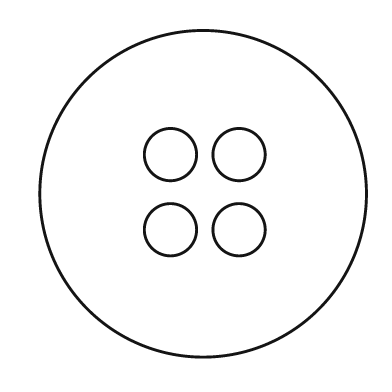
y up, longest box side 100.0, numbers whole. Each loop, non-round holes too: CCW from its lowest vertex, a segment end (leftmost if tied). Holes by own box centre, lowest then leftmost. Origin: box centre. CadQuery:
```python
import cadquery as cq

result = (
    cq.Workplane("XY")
    .moveTo(0.0, 0.0)
    .circle(50.0)
    .moveTo(-10.0, -11.0)
    .circle(8.0)
    .moveTo(11.0, -11.0)
    .circle(8.0)
    .moveTo(-10.0, 12.0)
    .circle(8.0)
    .moveTo(11.0, 12.0)
    .circle(8.0)
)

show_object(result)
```